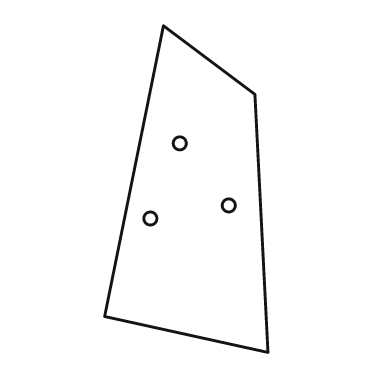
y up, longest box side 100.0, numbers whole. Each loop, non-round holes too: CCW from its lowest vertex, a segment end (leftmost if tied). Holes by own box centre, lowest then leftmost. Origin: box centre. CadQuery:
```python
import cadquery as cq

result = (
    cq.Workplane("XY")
    .moveTo(25.0, -50.0)
    .lineTo(21.0, 29.0)
    .lineTo(-7.0, 50.0)
    .lineTo(-25.0, -39.0)
    .close()
    .moveTo(-11.0, -9.0)
    .circle(2.0)
    .moveTo(13.0, -5.0)
    .circle(2.0)
    .moveTo(-2.0, 14.0)
    .circle(2.0)
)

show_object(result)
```